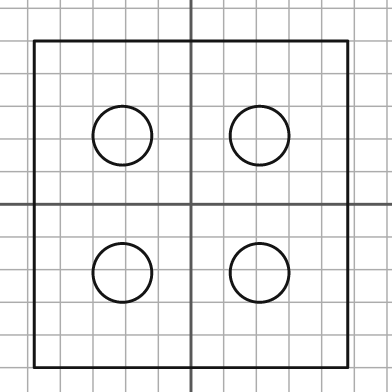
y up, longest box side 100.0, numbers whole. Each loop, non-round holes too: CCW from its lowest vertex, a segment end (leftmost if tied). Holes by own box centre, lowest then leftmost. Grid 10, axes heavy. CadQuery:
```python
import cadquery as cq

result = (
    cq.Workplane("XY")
    .moveTo(-48.0, -50.0)
    .lineTo(48.0, -50.0)
    .lineTo(48.0, 50.0)
    .lineTo(-48.0, 50.0)
    .close()
    .moveTo(-21.0, -21.0)
    .circle(9.0)
    .moveTo(21.0, -21.0)
    .circle(9.0)
    .moveTo(-21.0, 21.0)
    .circle(9.0)
    .moveTo(21.0, 21.0)
    .circle(9.0)
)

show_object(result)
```